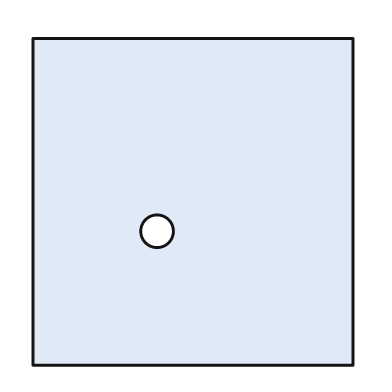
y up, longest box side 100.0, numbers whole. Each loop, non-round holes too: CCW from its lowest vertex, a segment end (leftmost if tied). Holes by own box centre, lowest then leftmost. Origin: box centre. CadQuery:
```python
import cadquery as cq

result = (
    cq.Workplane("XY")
    .moveTo(-49.0, -50.0)
    .lineTo(49.0, -50.0)
    .lineTo(49.0, 50.0)
    .lineTo(-49.0, 50.0)
    .close()
    .moveTo(-11.0, -9.0)
    .circle(5.0)
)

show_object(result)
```